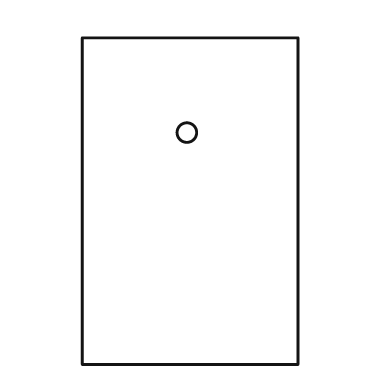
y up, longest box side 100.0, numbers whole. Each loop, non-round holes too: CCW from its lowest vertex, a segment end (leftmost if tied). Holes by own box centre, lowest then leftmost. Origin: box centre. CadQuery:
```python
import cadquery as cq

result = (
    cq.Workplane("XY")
    .moveTo(-33.0, -50.0)
    .lineTo(33.0, -50.0)
    .lineTo(33.0, 50.0)
    .lineTo(-33.0, 50.0)
    .close()
    .moveTo(-1.0, 21.0)
    .circle(3.0)
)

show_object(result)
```